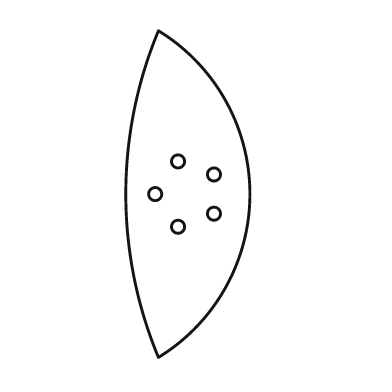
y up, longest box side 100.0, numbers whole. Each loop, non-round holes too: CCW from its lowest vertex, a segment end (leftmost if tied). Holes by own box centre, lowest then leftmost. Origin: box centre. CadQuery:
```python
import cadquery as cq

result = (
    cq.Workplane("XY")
    .moveTo(-9.0, -50.0)
    .threePointArc((19.0, 0.0), (-9.0, 50.0))
    .threePointArc((-19.0, 0.0), (-9.0, -50.0))
    .close()
    .moveTo(-3.0, -10.0)
    .circle(2.0)
    .moveTo(8.0, -6.0)
    .circle(2.0)
    .moveTo(-10.0, 0.0)
    .circle(2.0)
    .moveTo(8.0, 6.0)
    .circle(2.0)
    .moveTo(-3.0, 10.0)
    .circle(2.0)
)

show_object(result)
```